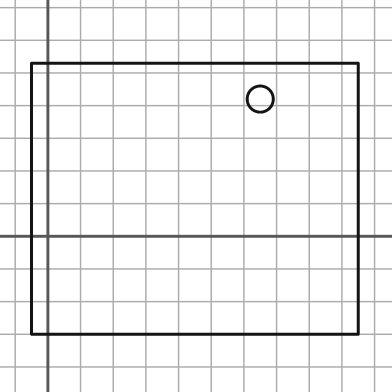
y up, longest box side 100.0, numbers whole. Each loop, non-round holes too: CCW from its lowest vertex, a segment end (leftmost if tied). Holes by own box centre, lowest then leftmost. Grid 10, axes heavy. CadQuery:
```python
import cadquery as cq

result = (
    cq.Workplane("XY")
    .moveTo(-5.0, -30.0)
    .lineTo(95.0, -30.0)
    .lineTo(95.0, 53.0)
    .lineTo(-5.0, 53.0)
    .close()
    .moveTo(65.0, 42.0)
    .circle(4.0)
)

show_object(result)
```